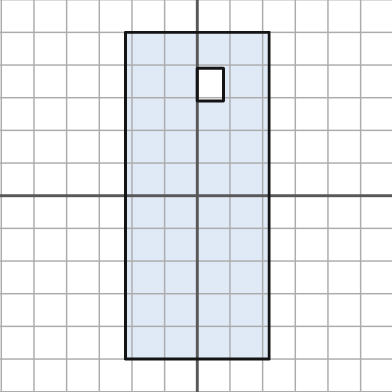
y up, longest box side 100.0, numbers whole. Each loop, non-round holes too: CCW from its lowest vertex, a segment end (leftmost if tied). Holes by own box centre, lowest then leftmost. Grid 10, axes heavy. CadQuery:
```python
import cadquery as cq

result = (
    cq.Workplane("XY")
    .moveTo(-22.0, -50.0)
    .lineTo(22.0, -50.0)
    .lineTo(22.0, 50.0)
    .lineTo(-22.0, 50.0)
    .close()
    .moveTo(0.0, 29.0)
    .lineTo(8.0, 29.0)
    .lineTo(8.0, 39.0)
    .lineTo(0.0, 39.0)
    .close()
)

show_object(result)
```